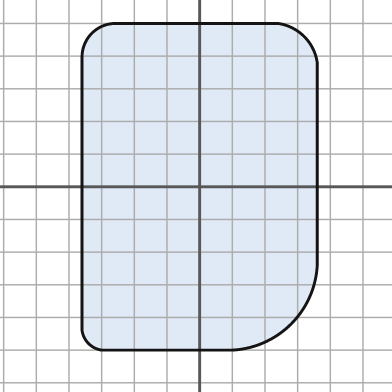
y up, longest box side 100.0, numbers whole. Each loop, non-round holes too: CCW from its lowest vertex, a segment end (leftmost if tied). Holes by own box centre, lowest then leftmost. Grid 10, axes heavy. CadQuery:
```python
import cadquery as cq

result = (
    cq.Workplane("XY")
    .moveTo(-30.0, -50.0)
    .lineTo(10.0, -50.0)
    .threePointArc((28.0, -42.0), (36.0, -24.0))
    .lineTo(36.0, 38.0)
    .threePointArc((32.0, 46.0), (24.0, 50.0))
    .lineTo(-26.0, 50.0)
    .threePointArc((-33.0, 47.0), (-36.0, 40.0))
    .lineTo(-36.0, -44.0)
    .threePointArc((-34.0, -48.0), (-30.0, -50.0))
    .close()
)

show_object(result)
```